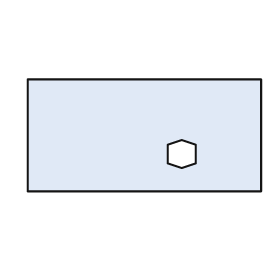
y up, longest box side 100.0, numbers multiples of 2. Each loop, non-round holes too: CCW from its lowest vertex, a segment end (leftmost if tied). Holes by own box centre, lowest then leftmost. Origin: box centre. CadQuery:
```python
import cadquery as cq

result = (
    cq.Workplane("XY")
    .moveTo(-50.0, -24.0)
    .lineTo(50.0, -24.0)
    .lineTo(50.0, 24.0)
    .lineTo(-50.0, 24.0)
    .close()
    .moveTo(16.0, -14.0)
    .lineTo(22.0, -12.0)
    .lineTo(22.0, -4.0)
    .lineTo(16.0, -2.0)
    .lineTo(10.0, -4.0)
    .lineTo(10.0, -12.0)
    .close()
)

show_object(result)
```